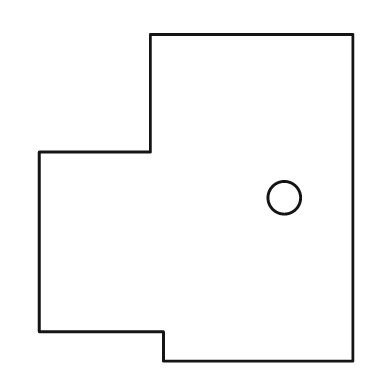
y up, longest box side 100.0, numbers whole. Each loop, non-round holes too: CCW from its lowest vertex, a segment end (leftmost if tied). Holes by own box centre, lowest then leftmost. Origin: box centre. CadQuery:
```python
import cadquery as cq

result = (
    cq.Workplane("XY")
    .moveTo(-10.0, -50.0)
    .lineTo(48.0, -50.0)
    .lineTo(48.0, 50.0)
    .lineTo(-14.0, 50.0)
    .lineTo(-14.0, 14.0)
    .lineTo(-48.0, 14.0)
    .lineTo(-48.0, -41.0)
    .lineTo(-10.0, -41.0)
    .close()
    .moveTo(27.0, 0.0)
    .circle(5.0)
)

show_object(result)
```